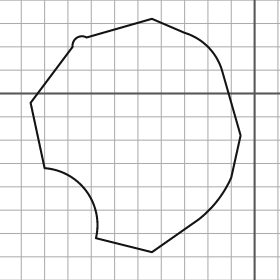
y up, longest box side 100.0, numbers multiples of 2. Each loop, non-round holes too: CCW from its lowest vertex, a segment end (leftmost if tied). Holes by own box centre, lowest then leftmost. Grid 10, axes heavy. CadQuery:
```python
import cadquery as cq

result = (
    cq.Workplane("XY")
    .moveTo(-44.0, -68.0)
    .lineTo(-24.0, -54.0)
    .threePointArc((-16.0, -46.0), (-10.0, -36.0))
    .lineTo(-6.0, -18.0)
    .lineTo(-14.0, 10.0)
    .threePointArc((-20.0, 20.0), (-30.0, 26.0))
    .lineTo(-44.0, 32.0)
    .lineTo(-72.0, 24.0)
    .threePointArc((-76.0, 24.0), (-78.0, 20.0))
    .lineTo(-96.0, -4.0)
    .lineTo(-90.0, -32.0)
    .threePointArc((-72.0, -42.0), (-68.0, -62.0))
    .close()
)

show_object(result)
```